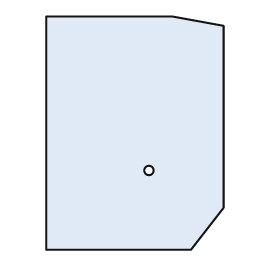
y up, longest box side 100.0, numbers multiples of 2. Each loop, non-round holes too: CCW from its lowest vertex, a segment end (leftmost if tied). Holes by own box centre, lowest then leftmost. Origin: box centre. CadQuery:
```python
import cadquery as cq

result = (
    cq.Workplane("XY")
    .moveTo(-38.0, -50.0)
    .lineTo(24.0, -50.0)
    .lineTo(38.0, -32.0)
    .lineTo(38.0, 46.0)
    .lineTo(16.0, 50.0)
    .lineTo(-38.0, 50.0)
    .close()
    .moveTo(6.0, -16.0)
    .circle(2.0)
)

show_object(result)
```